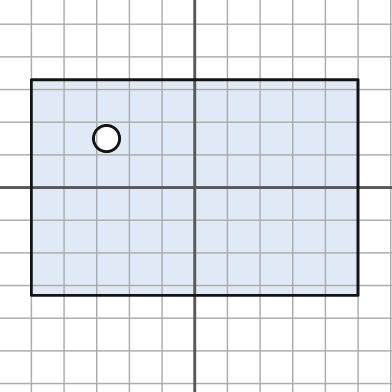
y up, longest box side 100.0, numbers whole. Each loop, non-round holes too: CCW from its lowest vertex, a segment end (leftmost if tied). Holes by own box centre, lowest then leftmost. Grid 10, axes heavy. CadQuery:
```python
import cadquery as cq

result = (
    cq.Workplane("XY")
    .moveTo(-50.0, -33.0)
    .lineTo(50.0, -33.0)
    .lineTo(50.0, 33.0)
    .lineTo(-50.0, 33.0)
    .close()
    .moveTo(-27.0, 15.0)
    .circle(4.0)
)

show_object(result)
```